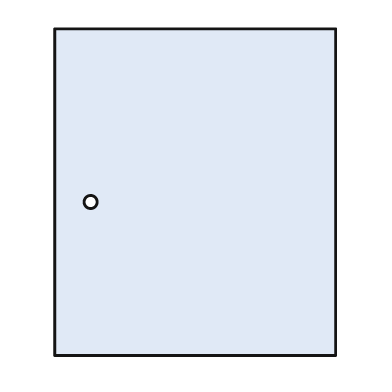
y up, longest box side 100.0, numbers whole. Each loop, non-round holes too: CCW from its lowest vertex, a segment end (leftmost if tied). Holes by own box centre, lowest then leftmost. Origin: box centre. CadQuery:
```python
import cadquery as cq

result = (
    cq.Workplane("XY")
    .moveTo(-43.0, -50.0)
    .lineTo(43.0, -50.0)
    .lineTo(43.0, 50.0)
    .lineTo(-43.0, 50.0)
    .close()
    .moveTo(-32.0, -3.0)
    .circle(2.0)
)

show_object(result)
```